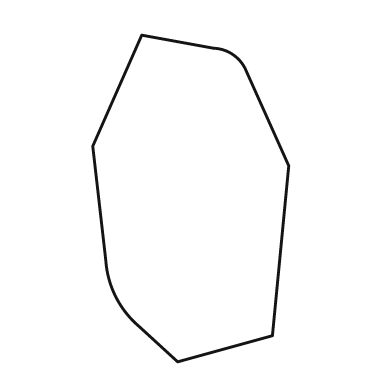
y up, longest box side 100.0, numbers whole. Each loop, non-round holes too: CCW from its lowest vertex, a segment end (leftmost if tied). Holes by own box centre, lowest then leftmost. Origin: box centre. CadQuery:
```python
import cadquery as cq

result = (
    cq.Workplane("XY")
    .moveTo(-4.0, -50.0)
    .lineTo(25.0, -42.0)
    .lineTo(30.0, 10.0)
    .lineTo(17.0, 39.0)
    .threePointArc((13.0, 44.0), (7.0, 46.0))
    .lineTo(-15.0, 50.0)
    .lineTo(-30.0, 16.0)
    .lineTo(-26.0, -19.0)
    .threePointArc((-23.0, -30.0), (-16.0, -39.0))
    .close()
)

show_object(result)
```